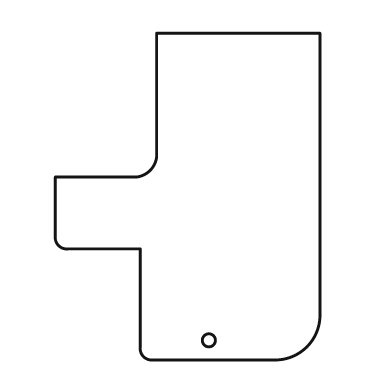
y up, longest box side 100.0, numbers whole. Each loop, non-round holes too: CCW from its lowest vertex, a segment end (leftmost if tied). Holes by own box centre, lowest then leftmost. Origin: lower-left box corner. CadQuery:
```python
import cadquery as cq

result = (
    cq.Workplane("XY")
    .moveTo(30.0, 0.0)
    .lineTo(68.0, 0.0)
    .threePointArc((77.0, 4.0), (81.0, 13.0))
    .lineTo(81.0, 100.0)
    .lineTo(31.0, 100.0)
    .lineTo(31.0, 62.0)
    .threePointArc((29.0, 58.0), (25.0, 56.0))
    .lineTo(0.0, 56.0)
    .lineTo(0.0, 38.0)
    .threePointArc((1.0, 35.0), (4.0, 34.0))
    .lineTo(26.0, 34.0)
    .lineTo(26.0, 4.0)
    .threePointArc((27.0, 1.0), (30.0, 0.0))
    .close()
    .moveTo(47.0, 6.0)
    .circle(2.0)
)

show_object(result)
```